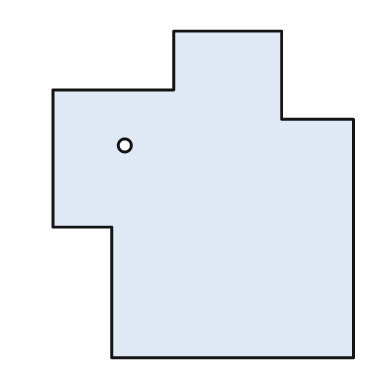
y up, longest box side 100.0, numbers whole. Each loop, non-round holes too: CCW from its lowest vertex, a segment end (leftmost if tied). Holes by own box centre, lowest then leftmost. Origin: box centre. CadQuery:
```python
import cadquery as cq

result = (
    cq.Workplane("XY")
    .moveTo(-28.0, -50.0)
    .lineTo(46.0, -50.0)
    .lineTo(46.0, 23.0)
    .lineTo(24.0, 23.0)
    .lineTo(24.0, 50.0)
    .lineTo(-9.0, 50.0)
    .lineTo(-9.0, 32.0)
    .lineTo(-46.0, 32.0)
    .lineTo(-46.0, -10.0)
    .lineTo(-28.0, -10.0)
    .close()
    .moveTo(-24.0, 15.0)
    .circle(2.0)
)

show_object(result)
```